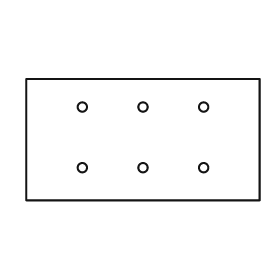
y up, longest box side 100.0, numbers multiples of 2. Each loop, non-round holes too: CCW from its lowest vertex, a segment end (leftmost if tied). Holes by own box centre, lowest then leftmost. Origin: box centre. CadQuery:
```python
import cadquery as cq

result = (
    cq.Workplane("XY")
    .moveTo(-50.0, -26.0)
    .lineTo(50.0, -26.0)
    .lineTo(50.0, 26.0)
    .lineTo(-50.0, 26.0)
    .close()
    .moveTo(-26.0, -12.0)
    .circle(2.0)
    .moveTo(0.0, -12.0)
    .circle(2.0)
    .moveTo(26.0, -12.0)
    .circle(2.0)
    .moveTo(-26.0, 14.0)
    .circle(2.0)
    .moveTo(0.0, 14.0)
    .circle(2.0)
    .moveTo(26.0, 14.0)
    .circle(2.0)
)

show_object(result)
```